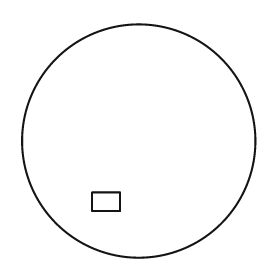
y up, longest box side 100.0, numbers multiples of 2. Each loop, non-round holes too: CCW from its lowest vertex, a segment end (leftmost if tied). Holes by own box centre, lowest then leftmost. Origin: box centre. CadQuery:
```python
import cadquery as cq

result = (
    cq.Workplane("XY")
    .moveTo(0.0, 0.0)
    .circle(50.0)
    .moveTo(-20.0, -30.0)
    .lineTo(-8.0, -30.0)
    .lineTo(-8.0, -22.0)
    .lineTo(-20.0, -22.0)
    .close()
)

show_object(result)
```